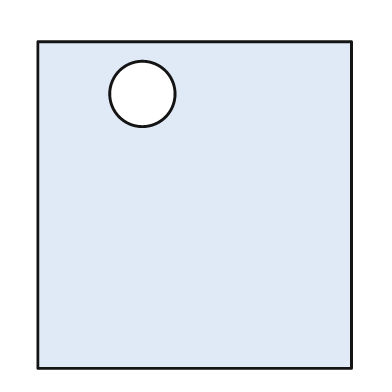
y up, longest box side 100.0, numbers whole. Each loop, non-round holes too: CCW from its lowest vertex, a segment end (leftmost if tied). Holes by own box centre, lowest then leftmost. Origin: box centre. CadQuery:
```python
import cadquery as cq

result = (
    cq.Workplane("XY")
    .moveTo(-48.0, -50.0)
    .lineTo(48.0, -50.0)
    .lineTo(48.0, 50.0)
    .lineTo(-48.0, 50.0)
    .close()
    .moveTo(-16.0, 34.0)
    .circle(10.0)
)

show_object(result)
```